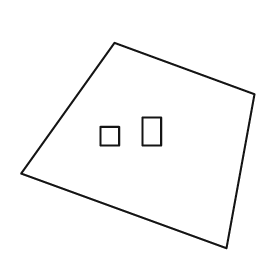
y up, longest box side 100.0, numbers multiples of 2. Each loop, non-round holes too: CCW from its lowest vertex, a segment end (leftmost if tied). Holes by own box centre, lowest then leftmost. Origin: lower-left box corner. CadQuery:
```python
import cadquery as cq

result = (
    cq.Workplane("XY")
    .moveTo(88.0, 0.0)
    .lineTo(100.0, 66.0)
    .lineTo(40.0, 88.0)
    .lineTo(0.0, 32.0)
    .close()
    .moveTo(34.0, 44.0)
    .lineTo(42.0, 44.0)
    .lineTo(42.0, 52.0)
    .lineTo(34.0, 52.0)
    .close()
    .moveTo(52.0, 44.0)
    .lineTo(60.0, 44.0)
    .lineTo(60.0, 56.0)
    .lineTo(52.0, 56.0)
    .close()
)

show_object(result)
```